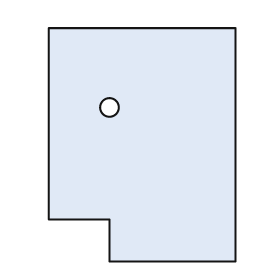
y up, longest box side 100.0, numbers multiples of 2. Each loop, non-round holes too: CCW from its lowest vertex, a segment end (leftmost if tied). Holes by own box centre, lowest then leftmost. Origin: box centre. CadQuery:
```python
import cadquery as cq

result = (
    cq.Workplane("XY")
    .moveTo(-14.0, -50.0)
    .lineTo(40.0, -50.0)
    .lineTo(40.0, 50.0)
    .lineTo(-40.0, 50.0)
    .lineTo(-40.0, -32.0)
    .lineTo(-14.0, -32.0)
    .close()
    .moveTo(-14.0, 16.0)
    .circle(4.0)
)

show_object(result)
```